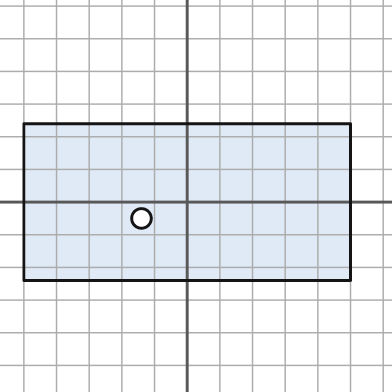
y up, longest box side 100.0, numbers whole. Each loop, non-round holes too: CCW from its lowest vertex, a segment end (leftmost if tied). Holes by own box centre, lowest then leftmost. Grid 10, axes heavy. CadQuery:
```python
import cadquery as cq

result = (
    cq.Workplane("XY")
    .moveTo(-50.0, -24.0)
    .lineTo(50.0, -24.0)
    .lineTo(50.0, 24.0)
    .lineTo(-50.0, 24.0)
    .close()
    .moveTo(-14.0, -5.0)
    .circle(3.0)
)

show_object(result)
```